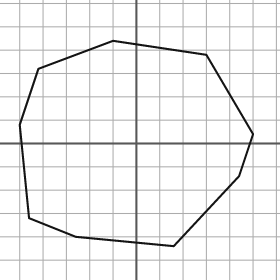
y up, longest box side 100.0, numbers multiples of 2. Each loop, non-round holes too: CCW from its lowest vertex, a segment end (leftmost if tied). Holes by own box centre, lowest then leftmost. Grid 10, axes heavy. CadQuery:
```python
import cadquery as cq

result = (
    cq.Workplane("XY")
    .moveTo(16.0, -44.0)
    .lineTo(44.0, -14.0)
    .lineTo(50.0, 4.0)
    .lineTo(30.0, 38.0)
    .lineTo(-10.0, 44.0)
    .lineTo(-42.0, 32.0)
    .lineTo(-50.0, 8.0)
    .lineTo(-46.0, -32.0)
    .lineTo(-26.0, -40.0)
    .close()
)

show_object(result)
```